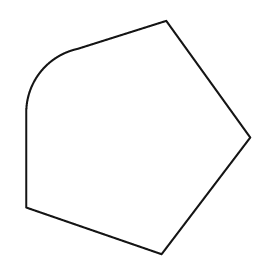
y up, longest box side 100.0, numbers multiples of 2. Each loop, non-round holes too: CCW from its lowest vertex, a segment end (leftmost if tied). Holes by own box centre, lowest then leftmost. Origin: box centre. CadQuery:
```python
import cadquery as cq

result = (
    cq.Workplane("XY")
    .moveTo(10.0, -50.0)
    .lineTo(48.0, 0.0)
    .lineTo(12.0, 50.0)
    .lineTo(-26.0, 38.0)
    .threePointArc((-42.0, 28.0), (-48.0, 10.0))
    .lineTo(-48.0, -30.0)
    .close()
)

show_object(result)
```